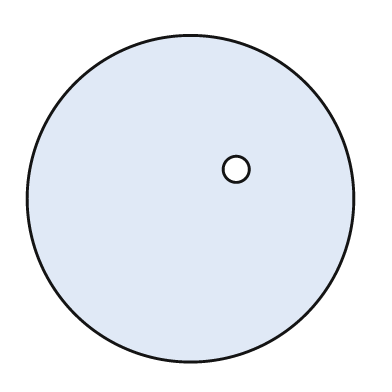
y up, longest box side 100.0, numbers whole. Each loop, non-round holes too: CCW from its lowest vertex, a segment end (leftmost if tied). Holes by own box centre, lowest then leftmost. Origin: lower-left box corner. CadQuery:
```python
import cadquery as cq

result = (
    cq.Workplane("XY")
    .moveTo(50.0, 50.0)
    .circle(50.0)
    .moveTo(64.0, 59.0)
    .circle(4.0)
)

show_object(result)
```